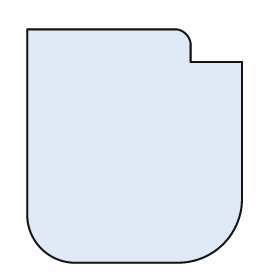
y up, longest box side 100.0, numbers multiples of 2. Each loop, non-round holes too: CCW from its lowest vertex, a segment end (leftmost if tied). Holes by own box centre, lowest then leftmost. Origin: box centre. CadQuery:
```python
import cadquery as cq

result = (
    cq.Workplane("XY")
    .moveTo(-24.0, -50.0)
    .lineTo(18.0, -50.0)
    .threePointArc((38.0, -42.0), (46.0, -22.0))
    .lineTo(46.0, 36.0)
    .lineTo(24.0, 36.0)
    .lineTo(24.0, 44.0)
    .threePointArc((22.0, 48.0), (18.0, 50.0))
    .lineTo(-46.0, 50.0)
    .lineTo(-46.0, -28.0)
    .threePointArc((-40.0, -44.0), (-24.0, -50.0))
    .close()
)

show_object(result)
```